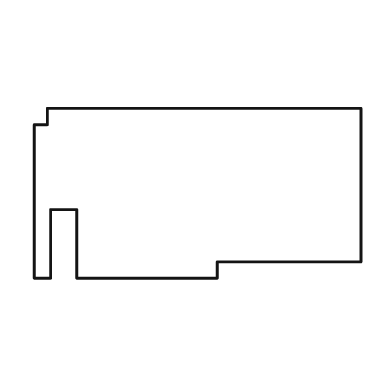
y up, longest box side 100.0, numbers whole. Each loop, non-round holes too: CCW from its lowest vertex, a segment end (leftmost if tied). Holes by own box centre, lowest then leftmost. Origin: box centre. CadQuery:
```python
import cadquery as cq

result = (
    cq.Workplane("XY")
    .moveTo(-50.0, -26.0)
    .lineTo(-45.0, -26.0)
    .lineTo(-45.0, -5.0)
    .lineTo(-37.0, -5.0)
    .lineTo(-37.0, -26.0)
    .lineTo(6.0, -26.0)
    .lineTo(6.0, -21.0)
    .lineTo(50.0, -21.0)
    .lineTo(50.0, 26.0)
    .lineTo(-46.0, 26.0)
    .lineTo(-46.0, 21.0)
    .lineTo(-50.0, 21.0)
    .close()
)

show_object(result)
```